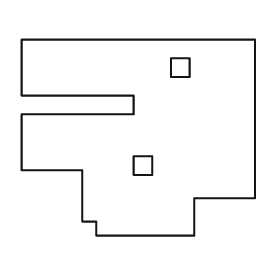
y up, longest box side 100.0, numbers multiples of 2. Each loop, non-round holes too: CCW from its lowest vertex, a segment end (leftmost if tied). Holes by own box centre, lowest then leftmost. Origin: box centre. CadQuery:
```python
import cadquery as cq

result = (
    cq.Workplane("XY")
    .moveTo(-18.0, -42.0)
    .lineTo(24.0, -42.0)
    .lineTo(24.0, -26.0)
    .lineTo(50.0, -26.0)
    .lineTo(50.0, 42.0)
    .lineTo(-50.0, 42.0)
    .lineTo(-50.0, 18.0)
    .lineTo(-2.0, 18.0)
    .lineTo(-2.0, 10.0)
    .lineTo(-50.0, 10.0)
    .lineTo(-50.0, -14.0)
    .lineTo(-24.0, -14.0)
    .lineTo(-24.0, -36.0)
    .lineTo(-18.0, -36.0)
    .close()
    .moveTo(-2.0, -16.0)
    .lineTo(6.0, -16.0)
    .lineTo(6.0, -8.0)
    .lineTo(-2.0, -8.0)
    .close()
    .moveTo(14.0, 26.0)
    .lineTo(22.0, 26.0)
    .lineTo(22.0, 34.0)
    .lineTo(14.0, 34.0)
    .close()
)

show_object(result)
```